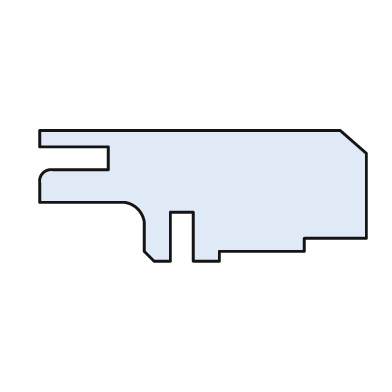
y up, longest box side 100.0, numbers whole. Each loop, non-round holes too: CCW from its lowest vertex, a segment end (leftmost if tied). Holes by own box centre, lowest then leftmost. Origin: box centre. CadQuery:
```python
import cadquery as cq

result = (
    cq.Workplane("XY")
    .moveTo(-15.0, -20.0)
    .lineTo(-10.0, -20.0)
    .lineTo(-10.0, -5.0)
    .lineTo(-3.0, -5.0)
    .lineTo(-3.0, -20.0)
    .lineTo(5.0, -20.0)
    .lineTo(5.0, -17.0)
    .lineTo(31.0, -17.0)
    .lineTo(31.0, -13.0)
    .lineTo(50.0, -13.0)
    .lineTo(50.0, 13.0)
    .lineTo(42.0, 20.0)
    .lineTo(-50.0, 20.0)
    .lineTo(-50.0, 15.0)
    .lineTo(-29.0, 15.0)
    .lineTo(-29.0, 8.0)
    .lineTo(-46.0, 8.0)
    .threePointArc((-49.0, 7.0), (-50.0, 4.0))
    .lineTo(-50.0, -2.0)
    .lineTo(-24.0, -2.0)
    .threePointArc((-20.0, -4.0), (-18.0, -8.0))
    .lineTo(-18.0, -17.0)
    .close()
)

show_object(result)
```